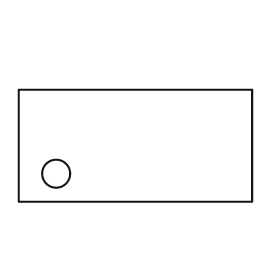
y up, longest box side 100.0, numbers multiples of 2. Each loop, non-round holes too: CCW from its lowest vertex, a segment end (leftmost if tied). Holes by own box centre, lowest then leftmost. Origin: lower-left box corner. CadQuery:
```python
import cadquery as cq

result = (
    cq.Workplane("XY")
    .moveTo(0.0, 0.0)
    .lineTo(100.0, 0.0)
    .lineTo(100.0, 48.0)
    .lineTo(0.0, 48.0)
    .close()
    .moveTo(16.0, 12.0)
    .circle(6.0)
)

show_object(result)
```